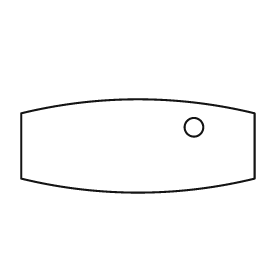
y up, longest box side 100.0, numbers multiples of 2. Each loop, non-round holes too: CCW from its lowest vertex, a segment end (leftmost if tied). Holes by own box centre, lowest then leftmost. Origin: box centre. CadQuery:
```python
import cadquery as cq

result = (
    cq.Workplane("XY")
    .moveTo(-50.0, -14.0)
    .threePointArc((0.0, -20.0), (50.0, -14.0))
    .lineTo(50.0, 14.0)
    .threePointArc((0.0, 20.0), (-50.0, 14.0))
    .close()
    .moveTo(24.0, 8.0)
    .circle(4.0)
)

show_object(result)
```